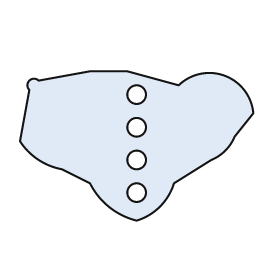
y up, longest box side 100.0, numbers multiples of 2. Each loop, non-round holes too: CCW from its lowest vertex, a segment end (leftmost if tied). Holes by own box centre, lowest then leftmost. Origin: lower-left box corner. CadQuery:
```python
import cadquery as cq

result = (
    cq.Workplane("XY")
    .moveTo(50.0, 0.0)
    .threePointArc((60.0, 6.0), (66.0, 16.0))
    .lineTo(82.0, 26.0)
    .threePointArc((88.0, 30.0), (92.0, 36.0))
    .lineTo(100.0, 46.0)
    .threePointArc((88.0, 62.0), (68.0, 58.0))
    .lineTo(46.0, 64.0)
    .lineTo(30.0, 64.0)
    .lineTo(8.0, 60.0)
    .threePointArc((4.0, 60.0), (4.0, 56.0))
    .lineTo(0.0, 34.0)
    .threePointArc((8.0, 26.0), (18.0, 22.0))
    .lineTo(30.0, 16.0)
    .threePointArc((38.0, 6.0), (50.0, 0.0))
    .close()
    .moveTo(50.0, 12.0)
    .circle(4.0)
    .moveTo(50.0, 26.0)
    .circle(4.0)
    .moveTo(50.0, 40.0)
    .circle(4.0)
    .moveTo(50.0, 54.0)
    .circle(4.0)
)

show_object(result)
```